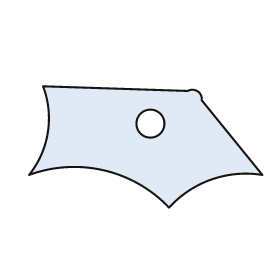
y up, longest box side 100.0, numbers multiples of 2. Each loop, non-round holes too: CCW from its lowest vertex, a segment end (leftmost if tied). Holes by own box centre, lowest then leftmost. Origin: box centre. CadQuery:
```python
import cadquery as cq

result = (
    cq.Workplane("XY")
    .moveTo(10.0, -26.0)
    .threePointArc((28.0, -14.0), (50.0, -12.0))
    .lineTo(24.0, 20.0)
    .threePointArc((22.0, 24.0), (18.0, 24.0))
    .lineTo(-44.0, 26.0)
    .threePointArc((-42.0, 6.0), (-50.0, -12.0))
    .threePointArc((-18.0, -10.0), (10.0, -26.0))
    .close()
    .moveTo(2.0, 10.0)
    .circle(6.0)
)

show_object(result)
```